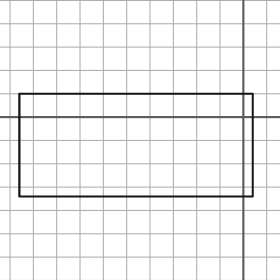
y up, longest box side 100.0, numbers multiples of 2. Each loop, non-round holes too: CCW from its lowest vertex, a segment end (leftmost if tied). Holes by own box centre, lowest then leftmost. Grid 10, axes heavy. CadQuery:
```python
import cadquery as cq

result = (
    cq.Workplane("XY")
    .moveTo(-96.0, -34.0)
    .lineTo(4.0, -34.0)
    .lineTo(4.0, 10.0)
    .lineTo(-96.0, 10.0)
    .close()
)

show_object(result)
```